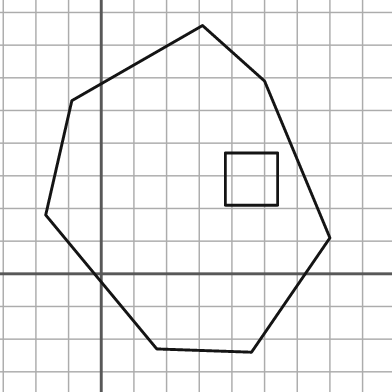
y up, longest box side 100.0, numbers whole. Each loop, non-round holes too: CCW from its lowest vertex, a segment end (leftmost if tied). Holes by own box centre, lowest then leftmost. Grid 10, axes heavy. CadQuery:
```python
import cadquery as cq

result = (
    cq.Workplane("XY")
    .moveTo(46.0, -24.0)
    .lineTo(70.0, 11.0)
    .lineTo(50.0, 59.0)
    .lineTo(31.0, 76.0)
    .lineTo(-9.0, 53.0)
    .lineTo(-17.0, 18.0)
    .lineTo(17.0, -23.0)
    .close()
    .moveTo(38.0, 21.0)
    .lineTo(54.0, 21.0)
    .lineTo(54.0, 37.0)
    .lineTo(38.0, 37.0)
    .close()
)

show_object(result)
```